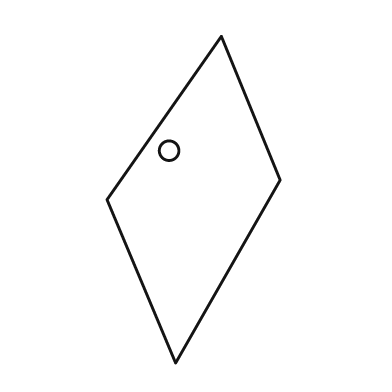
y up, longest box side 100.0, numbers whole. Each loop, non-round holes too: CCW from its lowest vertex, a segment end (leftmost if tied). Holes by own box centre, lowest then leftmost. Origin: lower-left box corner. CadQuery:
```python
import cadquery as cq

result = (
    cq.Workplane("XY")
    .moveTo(21.0, 0.0)
    .lineTo(53.0, 56.0)
    .lineTo(35.0, 100.0)
    .lineTo(0.0, 50.0)
    .close()
    .moveTo(19.0, 65.0)
    .circle(3.0)
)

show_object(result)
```